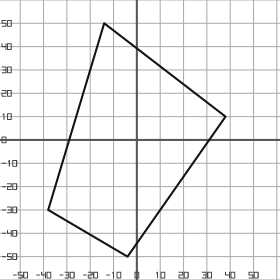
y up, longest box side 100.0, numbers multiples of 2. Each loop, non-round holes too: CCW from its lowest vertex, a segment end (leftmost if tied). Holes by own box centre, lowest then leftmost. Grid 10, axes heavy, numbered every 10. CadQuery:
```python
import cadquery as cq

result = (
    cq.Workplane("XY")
    .moveTo(-4.0, -50.0)
    .lineTo(38.0, 10.0)
    .lineTo(-14.0, 50.0)
    .lineTo(-38.0, -30.0)
    .close()
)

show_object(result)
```